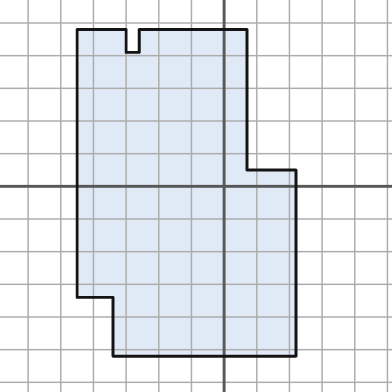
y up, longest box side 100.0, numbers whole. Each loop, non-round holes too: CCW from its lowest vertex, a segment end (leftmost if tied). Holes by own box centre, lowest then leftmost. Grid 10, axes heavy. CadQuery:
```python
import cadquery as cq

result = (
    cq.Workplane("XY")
    .moveTo(-34.0, -52.0)
    .lineTo(22.0, -52.0)
    .lineTo(22.0, 5.0)
    .lineTo(7.0, 5.0)
    .lineTo(7.0, 48.0)
    .lineTo(-26.0, 48.0)
    .lineTo(-26.0, 41.0)
    .lineTo(-30.0, 41.0)
    .lineTo(-30.0, 48.0)
    .lineTo(-45.0, 48.0)
    .lineTo(-45.0, -34.0)
    .lineTo(-34.0, -34.0)
    .close()
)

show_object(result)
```